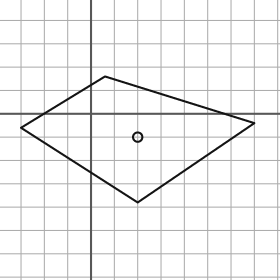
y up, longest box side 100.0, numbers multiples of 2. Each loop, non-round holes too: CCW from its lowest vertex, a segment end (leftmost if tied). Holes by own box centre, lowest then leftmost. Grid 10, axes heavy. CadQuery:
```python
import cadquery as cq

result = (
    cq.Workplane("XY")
    .moveTo(20.0, -38.0)
    .lineTo(70.0, -4.0)
    .lineTo(6.0, 16.0)
    .lineTo(-30.0, -6.0)
    .close()
    .moveTo(20.0, -10.0)
    .circle(2.0)
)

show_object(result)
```